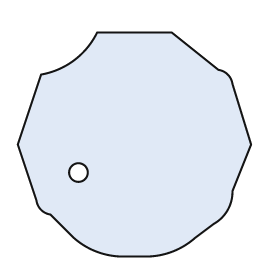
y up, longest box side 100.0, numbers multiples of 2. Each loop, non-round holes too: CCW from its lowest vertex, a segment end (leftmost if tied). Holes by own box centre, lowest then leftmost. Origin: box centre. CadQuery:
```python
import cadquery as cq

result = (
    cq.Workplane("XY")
    .moveTo(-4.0, -48.0)
    .lineTo(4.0, -48.0)
    .threePointArc((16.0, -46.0), (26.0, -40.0))
    .lineTo(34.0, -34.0)
    .threePointArc((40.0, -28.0), (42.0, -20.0))
    .lineTo(50.0, 0.0)
    .lineTo(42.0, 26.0)
    .threePointArc((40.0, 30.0), (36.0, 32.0))
    .lineTo(16.0, 48.0)
    .lineTo(-16.0, 48.0)
    .threePointArc((-26.0, 36.0), (-40.0, 30.0))
    .lineTo(-50.0, 0.0)
    .lineTo(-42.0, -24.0)
    .threePointArc((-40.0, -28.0), (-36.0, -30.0))
    .lineTo(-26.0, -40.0)
    .threePointArc((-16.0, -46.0), (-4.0, -48.0))
    .close()
    .moveTo(-24.0, -12.0)
    .circle(4.0)
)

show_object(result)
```